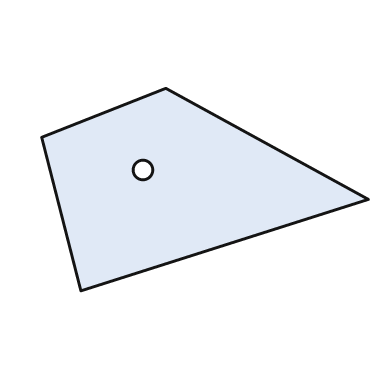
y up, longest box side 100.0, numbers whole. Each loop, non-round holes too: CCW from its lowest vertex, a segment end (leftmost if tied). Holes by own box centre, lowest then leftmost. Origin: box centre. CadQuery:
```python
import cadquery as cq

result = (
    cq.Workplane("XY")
    .moveTo(-38.0, -31.0)
    .lineTo(50.0, -3.0)
    .lineTo(-12.0, 31.0)
    .lineTo(-50.0, 16.0)
    .close()
    .moveTo(-19.0, 6.0)
    .circle(3.0)
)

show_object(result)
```